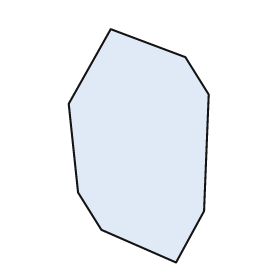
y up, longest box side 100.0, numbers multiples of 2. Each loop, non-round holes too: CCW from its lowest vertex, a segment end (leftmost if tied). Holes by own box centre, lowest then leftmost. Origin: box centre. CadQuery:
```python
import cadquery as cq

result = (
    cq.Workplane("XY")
    .moveTo(16.0, -50.0)
    .lineTo(28.0, -28.0)
    .lineTo(30.0, 22.0)
    .lineTo(20.0, 38.0)
    .lineTo(-12.0, 50.0)
    .lineTo(-30.0, 18.0)
    .lineTo(-26.0, -20.0)
    .lineTo(-16.0, -36.0)
    .close()
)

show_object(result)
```